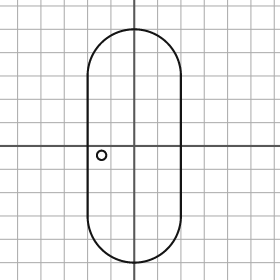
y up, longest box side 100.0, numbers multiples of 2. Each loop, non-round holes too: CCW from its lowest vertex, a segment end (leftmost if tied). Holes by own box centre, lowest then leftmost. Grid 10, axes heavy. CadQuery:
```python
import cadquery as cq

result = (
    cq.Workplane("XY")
    .moveTo(-20.0, -30.0)
    .threePointArc((0.0, -50.0), (20.0, -30.0))
    .lineTo(20.0, 30.0)
    .threePointArc((0.0, 50.0), (-20.0, 30.0))
    .close()
    .moveTo(-14.0, -4.0)
    .circle(2.0)
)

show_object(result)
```